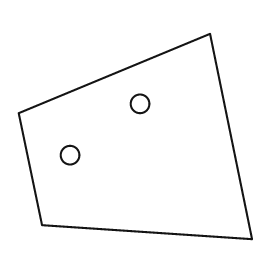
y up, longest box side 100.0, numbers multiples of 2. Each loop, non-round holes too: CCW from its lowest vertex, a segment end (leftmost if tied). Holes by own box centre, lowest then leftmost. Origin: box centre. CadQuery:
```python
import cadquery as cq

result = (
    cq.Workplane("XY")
    .moveTo(50.0, -44.0)
    .lineTo(32.0, 44.0)
    .lineTo(-50.0, 10.0)
    .lineTo(-40.0, -38.0)
    .close()
    .moveTo(-28.0, -8.0)
    .circle(4.0)
    .moveTo(2.0, 14.0)
    .circle(4.0)
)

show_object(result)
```